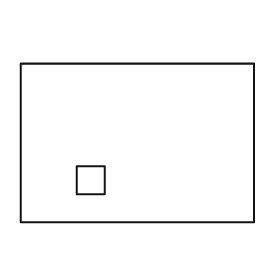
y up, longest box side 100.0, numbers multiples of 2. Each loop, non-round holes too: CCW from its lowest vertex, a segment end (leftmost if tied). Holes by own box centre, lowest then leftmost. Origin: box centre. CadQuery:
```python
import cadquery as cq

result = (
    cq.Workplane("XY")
    .moveTo(-50.0, -34.0)
    .lineTo(50.0, -34.0)
    .lineTo(50.0, 34.0)
    .lineTo(-50.0, 34.0)
    .close()
    .moveTo(-26.0, -22.0)
    .lineTo(-14.0, -22.0)
    .lineTo(-14.0, -10.0)
    .lineTo(-26.0, -10.0)
    .close()
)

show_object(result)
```